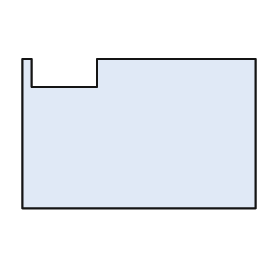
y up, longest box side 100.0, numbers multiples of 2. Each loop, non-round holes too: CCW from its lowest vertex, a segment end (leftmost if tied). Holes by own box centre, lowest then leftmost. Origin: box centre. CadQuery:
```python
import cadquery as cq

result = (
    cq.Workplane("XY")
    .moveTo(-50.0, -32.0)
    .lineTo(50.0, -32.0)
    .lineTo(50.0, 32.0)
    .lineTo(-18.0, 32.0)
    .lineTo(-18.0, 20.0)
    .lineTo(-46.0, 20.0)
    .lineTo(-46.0, 32.0)
    .lineTo(-50.0, 32.0)
    .close()
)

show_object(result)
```